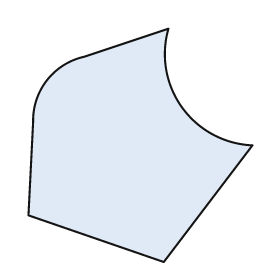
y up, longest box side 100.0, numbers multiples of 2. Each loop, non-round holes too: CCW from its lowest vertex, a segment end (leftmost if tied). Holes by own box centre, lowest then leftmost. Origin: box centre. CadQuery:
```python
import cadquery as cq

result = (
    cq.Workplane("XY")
    .moveTo(10.0, -50.0)
    .lineTo(48.0, 0.0)
    .threePointArc((18.0, 16.0), (12.0, 50.0))
    .lineTo(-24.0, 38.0)
    .threePointArc((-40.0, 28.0), (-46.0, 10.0))
    .lineTo(-48.0, -30.0)
    .close()
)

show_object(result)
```